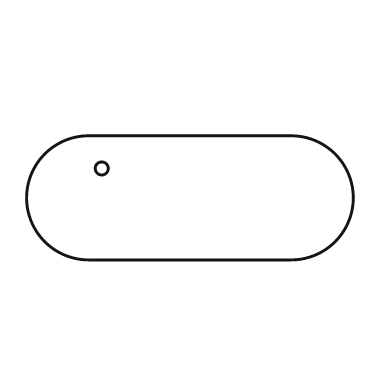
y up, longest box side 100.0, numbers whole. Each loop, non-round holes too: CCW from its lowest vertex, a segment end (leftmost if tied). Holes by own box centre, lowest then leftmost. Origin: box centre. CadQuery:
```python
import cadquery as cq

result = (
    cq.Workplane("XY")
    .moveTo(-31.0, -19.0)
    .lineTo(31.0, -19.0)
    .threePointArc((50.0, 0.0), (31.0, 19.0))
    .lineTo(-31.0, 19.0)
    .threePointArc((-50.0, 0.0), (-31.0, -19.0))
    .close()
    .moveTo(-27.0, 9.0)
    .circle(2.0)
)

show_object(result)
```